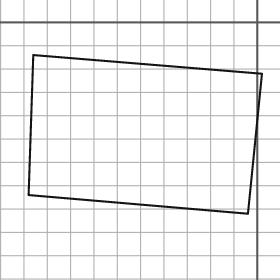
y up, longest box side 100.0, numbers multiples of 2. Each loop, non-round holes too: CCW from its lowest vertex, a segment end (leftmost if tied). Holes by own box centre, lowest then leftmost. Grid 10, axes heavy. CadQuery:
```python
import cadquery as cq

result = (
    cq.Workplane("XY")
    .moveTo(-4.0, -82.0)
    .lineTo(2.0, -22.0)
    .lineTo(-96.0, -14.0)
    .lineTo(-98.0, -74.0)
    .close()
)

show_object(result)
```